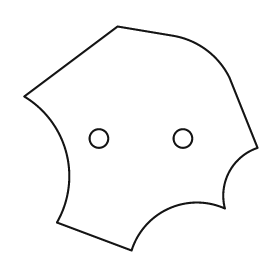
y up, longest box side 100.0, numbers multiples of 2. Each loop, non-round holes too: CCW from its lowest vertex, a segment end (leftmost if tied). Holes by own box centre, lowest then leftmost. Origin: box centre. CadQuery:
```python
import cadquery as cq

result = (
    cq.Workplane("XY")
    .moveTo(-4.0, -48.0)
    .threePointArc((12.0, -30.0), (36.0, -30.0))
    .threePointArc((38.0, -14.0), (50.0, -4.0))
    .lineTo(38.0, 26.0)
    .threePointArc((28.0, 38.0), (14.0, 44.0))
    .lineTo(-10.0, 48.0)
    .lineTo(-50.0, 18.0)
    .threePointArc((-32.0, -6.0), (-36.0, -36.0))
    .close()
    .moveTo(-18.0, 0.0)
    .circle(4.0)
    .moveTo(18.0, 0.0)
    .circle(4.0)
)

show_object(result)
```